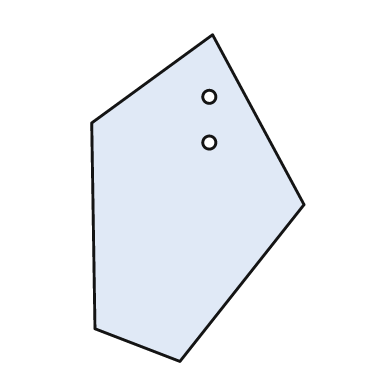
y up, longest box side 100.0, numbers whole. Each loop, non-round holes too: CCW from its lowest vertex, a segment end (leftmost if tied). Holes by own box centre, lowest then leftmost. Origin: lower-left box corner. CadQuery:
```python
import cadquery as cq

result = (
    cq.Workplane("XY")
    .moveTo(27.0, 0.0)
    .lineTo(65.0, 48.0)
    .lineTo(37.0, 100.0)
    .lineTo(0.0, 73.0)
    .lineTo(1.0, 10.0)
    .close()
    .moveTo(36.0, 67.0)
    .circle(2.0)
    .moveTo(36.0, 81.0)
    .circle(2.0)
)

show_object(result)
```